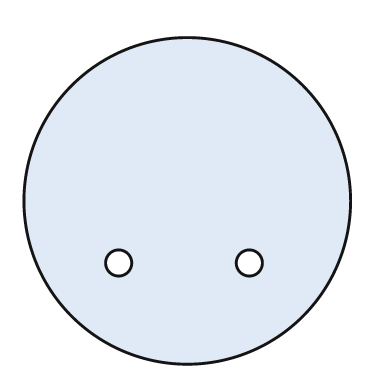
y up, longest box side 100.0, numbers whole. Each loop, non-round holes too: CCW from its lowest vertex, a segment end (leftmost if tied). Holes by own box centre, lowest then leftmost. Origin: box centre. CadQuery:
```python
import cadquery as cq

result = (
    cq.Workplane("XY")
    .moveTo(0.0, 0.0)
    .circle(50.0)
    .moveTo(-21.0, -19.0)
    .circle(4.0)
    .moveTo(19.0, -19.0)
    .circle(4.0)
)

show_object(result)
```